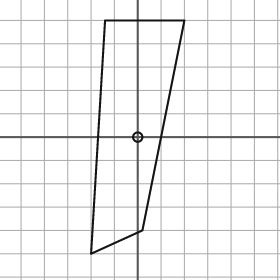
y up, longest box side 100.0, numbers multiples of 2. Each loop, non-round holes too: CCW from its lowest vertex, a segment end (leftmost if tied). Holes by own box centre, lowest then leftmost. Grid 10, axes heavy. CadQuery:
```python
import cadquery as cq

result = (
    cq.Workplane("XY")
    .moveTo(-20.0, -50.0)
    .lineTo(2.0, -40.0)
    .lineTo(20.0, 50.0)
    .lineTo(-14.0, 50.0)
    .close()
    .moveTo(0.0, 0.0)
    .circle(2.0)
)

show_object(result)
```